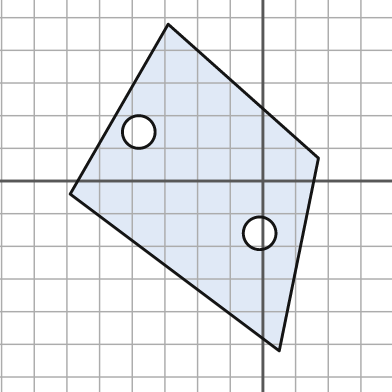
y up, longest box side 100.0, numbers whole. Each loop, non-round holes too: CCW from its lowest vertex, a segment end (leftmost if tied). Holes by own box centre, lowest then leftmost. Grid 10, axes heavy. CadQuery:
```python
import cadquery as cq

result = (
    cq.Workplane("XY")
    .moveTo(5.0, -52.0)
    .lineTo(17.0, 7.0)
    .lineTo(-29.0, 48.0)
    .lineTo(-59.0, -4.0)
    .close()
    .moveTo(-1.0, -16.0)
    .circle(5.0)
    .moveTo(-38.0, 15.0)
    .circle(5.0)
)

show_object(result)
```